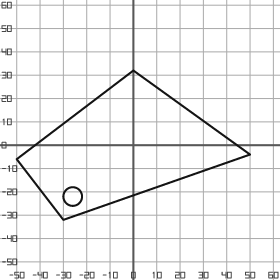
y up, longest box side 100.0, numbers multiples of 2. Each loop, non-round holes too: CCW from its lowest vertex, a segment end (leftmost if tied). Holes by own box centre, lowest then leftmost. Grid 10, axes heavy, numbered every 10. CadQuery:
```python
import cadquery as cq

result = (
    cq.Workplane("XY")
    .moveTo(-30.0, -32.0)
    .lineTo(50.0, -4.0)
    .lineTo(0.0, 32.0)
    .lineTo(-50.0, -6.0)
    .close()
    .moveTo(-26.0, -22.0)
    .circle(4.0)
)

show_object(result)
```